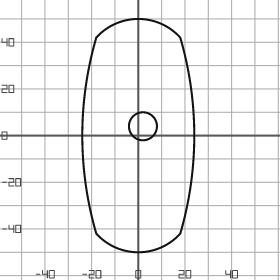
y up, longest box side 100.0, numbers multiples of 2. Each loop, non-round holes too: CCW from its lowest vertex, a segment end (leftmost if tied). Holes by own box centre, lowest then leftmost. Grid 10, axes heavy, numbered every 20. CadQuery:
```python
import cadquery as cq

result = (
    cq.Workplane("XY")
    .moveTo(-18.0, -42.0)
    .threePointArc((0.0, -50.0), (18.0, -42.0))
    .threePointArc((24.0, 0.0), (18.0, 42.0))
    .threePointArc((0.0, 50.0), (-18.0, 42.0))
    .threePointArc((-24.0, 0.0), (-18.0, -42.0))
    .close()
    .moveTo(2.0, 4.0)
    .circle(6.0)
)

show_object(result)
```